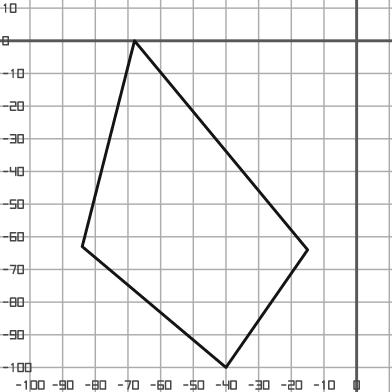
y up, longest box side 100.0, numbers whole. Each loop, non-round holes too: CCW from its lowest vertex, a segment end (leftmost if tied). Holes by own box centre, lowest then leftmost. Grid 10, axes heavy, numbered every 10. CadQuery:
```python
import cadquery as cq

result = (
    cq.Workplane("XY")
    .moveTo(-40.0, -100.0)
    .lineTo(-15.0, -64.0)
    .lineTo(-68.0, 0.0)
    .lineTo(-84.0, -63.0)
    .close()
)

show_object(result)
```